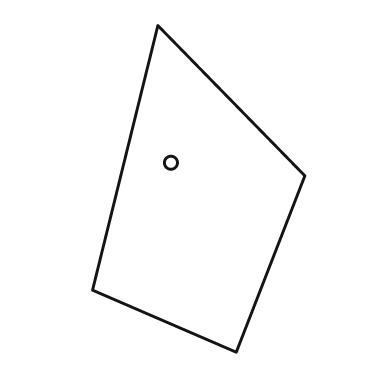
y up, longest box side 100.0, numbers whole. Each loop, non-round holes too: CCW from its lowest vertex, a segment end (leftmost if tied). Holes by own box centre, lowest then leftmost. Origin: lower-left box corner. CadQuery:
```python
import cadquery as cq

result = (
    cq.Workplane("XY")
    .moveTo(44.0, 0.0)
    .lineTo(65.0, 54.0)
    .lineTo(20.0, 100.0)
    .lineTo(0.0, 19.0)
    .close()
    .moveTo(24.0, 58.0)
    .circle(2.0)
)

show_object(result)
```